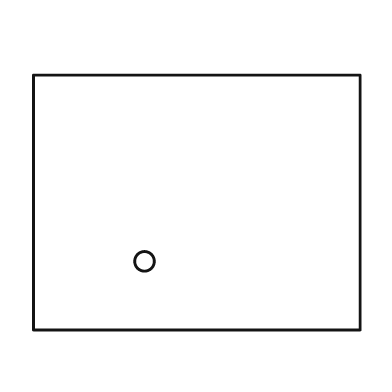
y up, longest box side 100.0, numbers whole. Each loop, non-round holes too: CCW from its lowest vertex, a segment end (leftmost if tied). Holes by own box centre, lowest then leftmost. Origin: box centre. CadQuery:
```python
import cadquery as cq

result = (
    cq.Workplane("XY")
    .moveTo(-50.0, -39.0)
    .lineTo(50.0, -39.0)
    .lineTo(50.0, 39.0)
    .lineTo(-50.0, 39.0)
    .close()
    .moveTo(-16.0, -18.0)
    .circle(3.0)
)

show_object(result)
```